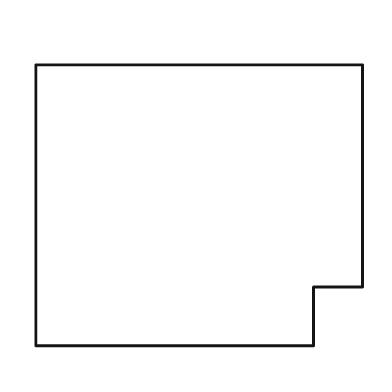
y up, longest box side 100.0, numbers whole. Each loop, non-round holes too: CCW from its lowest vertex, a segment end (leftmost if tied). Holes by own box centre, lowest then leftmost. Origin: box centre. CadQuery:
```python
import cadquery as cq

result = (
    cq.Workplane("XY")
    .moveTo(-50.0, -43.0)
    .lineTo(35.0, -43.0)
    .lineTo(35.0, -25.0)
    .lineTo(50.0, -25.0)
    .lineTo(50.0, 43.0)
    .lineTo(-50.0, 43.0)
    .close()
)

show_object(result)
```